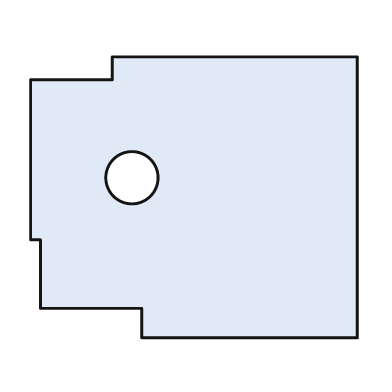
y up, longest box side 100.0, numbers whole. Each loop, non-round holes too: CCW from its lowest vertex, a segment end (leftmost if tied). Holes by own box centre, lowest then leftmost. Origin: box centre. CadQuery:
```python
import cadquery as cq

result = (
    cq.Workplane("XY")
    .moveTo(-16.0, -43.0)
    .lineTo(50.0, -43.0)
    .lineTo(50.0, 43.0)
    .lineTo(-25.0, 43.0)
    .lineTo(-25.0, 36.0)
    .lineTo(-50.0, 36.0)
    .lineTo(-50.0, -13.0)
    .lineTo(-47.0, -13.0)
    .lineTo(-47.0, -34.0)
    .lineTo(-16.0, -34.0)
    .close()
    .moveTo(-19.0, 6.0)
    .circle(8.0)
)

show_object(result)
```